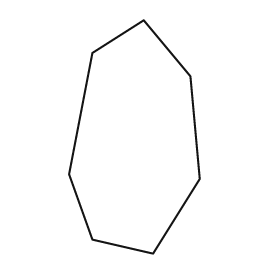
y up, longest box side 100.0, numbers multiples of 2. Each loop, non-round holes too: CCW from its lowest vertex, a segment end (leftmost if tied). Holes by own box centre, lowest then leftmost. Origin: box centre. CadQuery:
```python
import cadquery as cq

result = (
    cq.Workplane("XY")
    .moveTo(8.0, -50.0)
    .lineTo(28.0, -18.0)
    .lineTo(24.0, 26.0)
    .lineTo(4.0, 50.0)
    .lineTo(-18.0, 36.0)
    .lineTo(-28.0, -16.0)
    .lineTo(-18.0, -44.0)
    .close()
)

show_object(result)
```